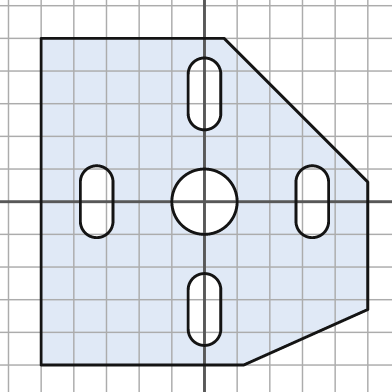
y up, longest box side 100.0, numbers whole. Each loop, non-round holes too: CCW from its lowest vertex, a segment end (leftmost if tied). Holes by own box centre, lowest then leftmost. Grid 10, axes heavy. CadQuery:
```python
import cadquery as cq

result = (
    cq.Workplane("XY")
    .moveTo(-50.0, -50.0)
    .lineTo(12.0, -50.0)
    .lineTo(50.0, -33.0)
    .lineTo(50.0, 6.0)
    .lineTo(6.0, 50.0)
    .lineTo(-50.0, 50.0)
    .close()
    .moveTo(-5.0, -39.0)
    .threePointArc((0.0, -44.0), (5.0, -39.0))
    .lineTo(5.0, -27.0)
    .threePointArc((0.0, -22.0), (-5.0, -27.0))
    .close()
    .moveTo(-38.0, -6.0)
    .threePointArc((-33.0, -11.0), (-28.0, -6.0))
    .lineTo(-28.0, 6.0)
    .threePointArc((-33.0, 11.0), (-38.0, 6.0))
    .close()
    .moveTo(0.0, 0.0)
    .circle(10.0)
    .moveTo(28.0, -6.0)
    .threePointArc((33.0, -11.0), (38.0, -6.0))
    .lineTo(38.0, 6.0)
    .threePointArc((33.0, 11.0), (28.0, 6.0))
    .close()
    .moveTo(-5.0, 27.0)
    .threePointArc((0.0, 22.0), (5.0, 27.0))
    .lineTo(5.0, 39.0)
    .threePointArc((0.0, 44.0), (-5.0, 39.0))
    .close()
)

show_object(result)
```